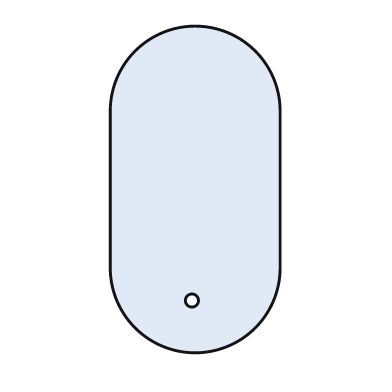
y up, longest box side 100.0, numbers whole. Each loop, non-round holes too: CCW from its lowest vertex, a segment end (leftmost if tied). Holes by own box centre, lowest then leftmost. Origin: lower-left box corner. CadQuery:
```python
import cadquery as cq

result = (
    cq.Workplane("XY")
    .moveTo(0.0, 26.0)
    .threePointArc((26.0, 0.0), (52.0, 26.0))
    .lineTo(52.0, 74.0)
    .threePointArc((26.0, 100.0), (0.0, 74.0))
    .close()
    .moveTo(25.0, 16.0)
    .circle(2.0)
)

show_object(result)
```